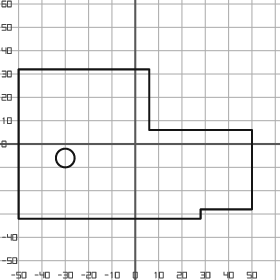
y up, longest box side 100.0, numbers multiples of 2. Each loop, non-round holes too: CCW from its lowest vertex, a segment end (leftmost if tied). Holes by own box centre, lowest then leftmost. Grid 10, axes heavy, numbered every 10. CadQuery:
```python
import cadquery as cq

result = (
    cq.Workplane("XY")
    .moveTo(-50.0, -32.0)
    .lineTo(28.0, -32.0)
    .lineTo(28.0, -28.0)
    .lineTo(50.0, -28.0)
    .lineTo(50.0, 6.0)
    .lineTo(6.0, 6.0)
    .lineTo(6.0, 32.0)
    .lineTo(-50.0, 32.0)
    .close()
    .moveTo(-30.0, -6.0)
    .circle(4.0)
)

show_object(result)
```